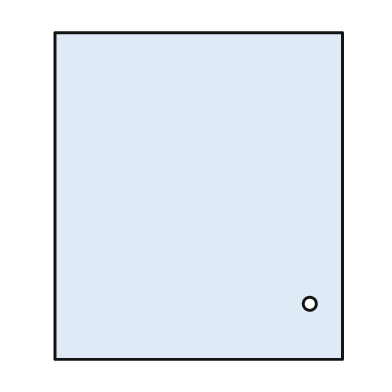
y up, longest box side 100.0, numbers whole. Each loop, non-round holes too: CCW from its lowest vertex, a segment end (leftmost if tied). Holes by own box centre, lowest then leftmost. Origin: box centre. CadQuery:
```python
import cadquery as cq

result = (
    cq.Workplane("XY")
    .moveTo(-44.0, -50.0)
    .lineTo(44.0, -50.0)
    .lineTo(44.0, 50.0)
    .lineTo(-44.0, 50.0)
    .close()
    .moveTo(34.0, -33.0)
    .circle(2.0)
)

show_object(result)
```